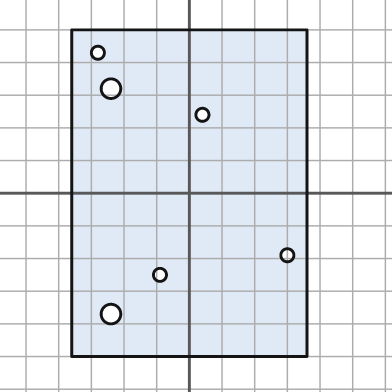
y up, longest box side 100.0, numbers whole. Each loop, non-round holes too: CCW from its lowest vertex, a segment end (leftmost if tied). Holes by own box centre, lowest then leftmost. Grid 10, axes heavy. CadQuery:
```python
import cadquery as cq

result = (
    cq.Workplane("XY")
    .moveTo(-36.0, -50.0)
    .lineTo(36.0, -50.0)
    .lineTo(36.0, 50.0)
    .lineTo(-36.0, 50.0)
    .close()
    .moveTo(-24.0, -37.0)
    .circle(3.0)
    .moveTo(-9.0, -25.0)
    .circle(2.0)
    .moveTo(30.0, -19.0)
    .circle(2.0)
    .moveTo(4.0, 24.0)
    .circle(2.0)
    .moveTo(-24.0, 32.0)
    .circle(3.0)
    .moveTo(-28.0, 43.0)
    .circle(2.0)
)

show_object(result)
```